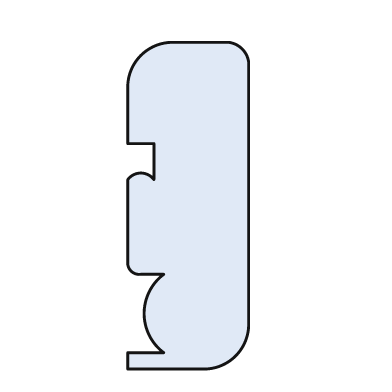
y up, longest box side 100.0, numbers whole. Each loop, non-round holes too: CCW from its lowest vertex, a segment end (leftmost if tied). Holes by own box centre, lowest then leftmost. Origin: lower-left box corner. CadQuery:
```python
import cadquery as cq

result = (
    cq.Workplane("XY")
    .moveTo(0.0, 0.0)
    .lineTo(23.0, 0.0)
    .threePointArc((33.0, 4.0), (37.0, 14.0))
    .lineTo(37.0, 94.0)
    .threePointArc((35.0, 98.0), (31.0, 100.0))
    .lineTo(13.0, 100.0)
    .threePointArc((4.0, 96.0), (0.0, 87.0))
    .lineTo(0.0, 69.0)
    .lineTo(8.0, 69.0)
    .lineTo(8.0, 58.0)
    .threePointArc((4.0, 60.0), (0.0, 58.0))
    .lineTo(0.0, 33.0)
    .threePointArc((1.0, 30.0), (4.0, 29.0))
    .lineTo(11.0, 29.0)
    .threePointArc((5.0, 17.0), (11.0, 5.0))
    .lineTo(0.0, 5.0)
    .close()
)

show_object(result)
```